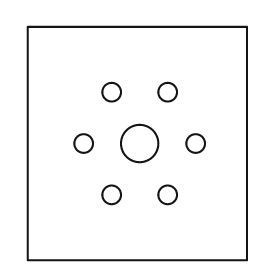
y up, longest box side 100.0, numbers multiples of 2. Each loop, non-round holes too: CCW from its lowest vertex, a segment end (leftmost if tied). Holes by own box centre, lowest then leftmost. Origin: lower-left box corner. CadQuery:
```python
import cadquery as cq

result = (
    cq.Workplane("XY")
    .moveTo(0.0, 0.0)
    .lineTo(94.0, 0.0)
    .lineTo(94.0, 100.0)
    .lineTo(0.0, 100.0)
    .close()
    .moveTo(36.0, 28.0)
    .circle(4.0)
    .moveTo(60.0, 28.0)
    .circle(4.0)
    .moveTo(24.0, 50.0)
    .circle(4.0)
    .moveTo(48.0, 50.0)
    .circle(8.0)
    .moveTo(72.0, 50.0)
    .circle(4.0)
    .moveTo(36.0, 72.0)
    .circle(4.0)
    .moveTo(60.0, 72.0)
    .circle(4.0)
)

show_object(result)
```